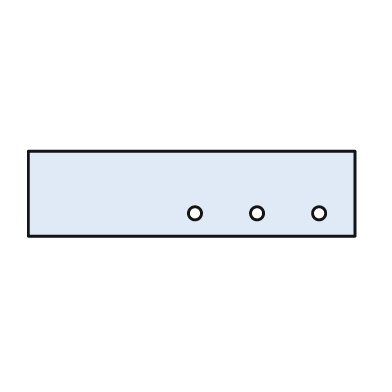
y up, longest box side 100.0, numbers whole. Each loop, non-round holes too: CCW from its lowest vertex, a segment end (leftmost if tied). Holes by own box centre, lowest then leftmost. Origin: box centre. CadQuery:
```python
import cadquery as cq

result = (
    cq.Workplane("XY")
    .moveTo(-50.0, -13.0)
    .lineTo(50.0, -13.0)
    .lineTo(50.0, 13.0)
    .lineTo(-50.0, 13.0)
    .close()
    .moveTo(1.0, -6.0)
    .circle(2.0)
    .moveTo(20.0, -6.0)
    .circle(2.0)
    .moveTo(39.0, -6.0)
    .circle(2.0)
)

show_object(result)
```